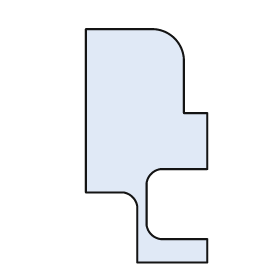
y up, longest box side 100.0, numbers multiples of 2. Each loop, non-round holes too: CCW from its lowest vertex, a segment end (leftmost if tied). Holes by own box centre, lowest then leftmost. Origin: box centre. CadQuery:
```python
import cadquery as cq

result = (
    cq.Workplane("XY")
    .moveTo(-4.0, -50.0)
    .lineTo(26.0, -50.0)
    .lineTo(26.0, -40.0)
    .lineTo(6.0, -40.0)
    .threePointArc((2.0, -38.0), (0.0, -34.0))
    .lineTo(0.0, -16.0)
    .threePointArc((2.0, -12.0), (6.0, -10.0))
    .lineTo(26.0, -10.0)
    .lineTo(26.0, 14.0)
    .lineTo(16.0, 14.0)
    .lineTo(16.0, 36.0)
    .threePointArc((12.0, 46.0), (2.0, 50.0))
    .lineTo(-26.0, 50.0)
    .lineTo(-26.0, -20.0)
    .lineTo(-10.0, -20.0)
    .threePointArc((-6.0, -22.0), (-4.0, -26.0))
    .close()
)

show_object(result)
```